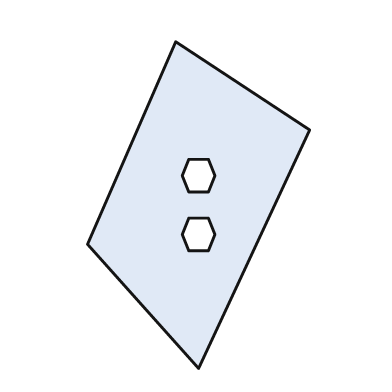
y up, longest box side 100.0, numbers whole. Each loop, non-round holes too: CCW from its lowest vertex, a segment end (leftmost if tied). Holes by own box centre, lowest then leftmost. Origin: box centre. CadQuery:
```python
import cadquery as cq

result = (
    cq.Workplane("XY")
    .moveTo(0.0, -50.0)
    .lineTo(34.0, 23.0)
    .lineTo(-7.0, 50.0)
    .lineTo(-34.0, -12.0)
    .close()
    .moveTo(-3.0, -14.0)
    .lineTo(3.0, -14.0)
    .lineTo(5.0, -9.0)
    .lineTo(3.0, -4.0)
    .lineTo(-3.0, -4.0)
    .lineTo(-5.0, -9.0)
    .close()
    .moveTo(-3.0, 4.0)
    .lineTo(3.0, 4.0)
    .lineTo(5.0, 9.0)
    .lineTo(3.0, 14.0)
    .lineTo(-3.0, 14.0)
    .lineTo(-5.0, 9.0)
    .close()
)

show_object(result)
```